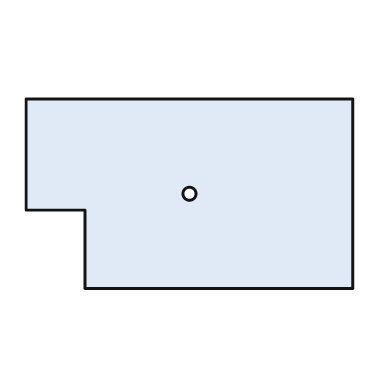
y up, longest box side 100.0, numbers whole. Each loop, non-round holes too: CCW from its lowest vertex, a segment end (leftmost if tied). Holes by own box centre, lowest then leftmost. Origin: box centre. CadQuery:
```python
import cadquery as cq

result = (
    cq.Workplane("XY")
    .moveTo(-32.0, -29.0)
    .lineTo(50.0, -29.0)
    .lineTo(50.0, 29.0)
    .lineTo(-50.0, 29.0)
    .lineTo(-50.0, -5.0)
    .lineTo(-32.0, -5.0)
    .close()
    .moveTo(0.0, 0.0)
    .circle(2.0)
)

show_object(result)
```